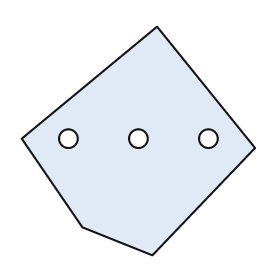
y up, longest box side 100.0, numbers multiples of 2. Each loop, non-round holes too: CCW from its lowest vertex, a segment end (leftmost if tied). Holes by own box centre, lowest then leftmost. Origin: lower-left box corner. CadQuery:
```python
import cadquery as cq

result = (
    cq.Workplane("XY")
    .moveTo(56.0, 0.0)
    .lineTo(100.0, 46.0)
    .lineTo(58.0, 98.0)
    .lineTo(0.0, 50.0)
    .lineTo(26.0, 12.0)
    .close()
    .moveTo(20.0, 50.0)
    .circle(4.0)
    .moveTo(50.0, 50.0)
    .circle(4.0)
    .moveTo(80.0, 50.0)
    .circle(4.0)
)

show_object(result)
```